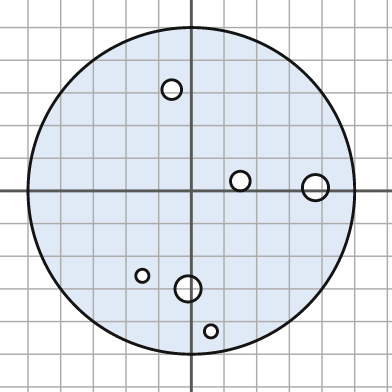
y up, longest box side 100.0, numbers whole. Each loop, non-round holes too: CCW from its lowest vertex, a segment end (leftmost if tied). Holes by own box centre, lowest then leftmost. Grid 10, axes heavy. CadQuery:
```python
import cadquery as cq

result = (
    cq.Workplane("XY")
    .moveTo(0.0, 0.0)
    .circle(50.0)
    .moveTo(6.0, -43.0)
    .circle(2.0)
    .moveTo(-1.0, -30.0)
    .circle(4.0)
    .moveTo(-15.0, -26.0)
    .circle(2.0)
    .moveTo(38.0, 1.0)
    .circle(4.0)
    .moveTo(15.0, 3.0)
    .circle(3.0)
    .moveTo(-6.0, 31.0)
    .circle(3.0)
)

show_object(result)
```